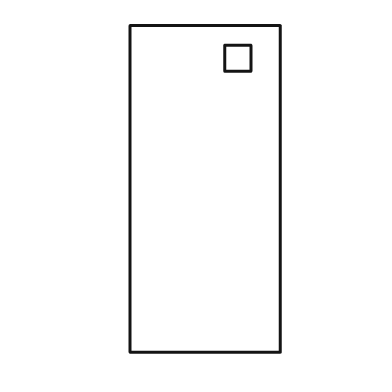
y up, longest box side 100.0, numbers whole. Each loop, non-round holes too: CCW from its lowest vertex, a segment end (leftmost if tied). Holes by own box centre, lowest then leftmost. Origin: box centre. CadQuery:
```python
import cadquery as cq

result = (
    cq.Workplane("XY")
    .moveTo(-23.0, -50.0)
    .lineTo(23.0, -50.0)
    .lineTo(23.0, 50.0)
    .lineTo(-23.0, 50.0)
    .close()
    .moveTo(6.0, 36.0)
    .lineTo(14.0, 36.0)
    .lineTo(14.0, 44.0)
    .lineTo(6.0, 44.0)
    .close()
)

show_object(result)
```